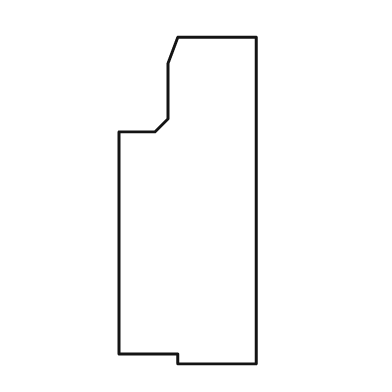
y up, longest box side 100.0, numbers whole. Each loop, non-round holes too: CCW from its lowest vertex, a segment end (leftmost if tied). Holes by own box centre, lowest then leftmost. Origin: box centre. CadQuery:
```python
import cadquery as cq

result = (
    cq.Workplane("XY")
    .moveTo(-3.0, -50.0)
    .lineTo(21.0, -50.0)
    .lineTo(21.0, 50.0)
    .lineTo(-3.0, 50.0)
    .lineTo(-6.0, 42.0)
    .lineTo(-6.0, 25.0)
    .lineTo(-10.0, 21.0)
    .lineTo(-21.0, 21.0)
    .lineTo(-21.0, -47.0)
    .lineTo(-3.0, -47.0)
    .close()
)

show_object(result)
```